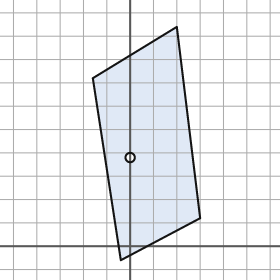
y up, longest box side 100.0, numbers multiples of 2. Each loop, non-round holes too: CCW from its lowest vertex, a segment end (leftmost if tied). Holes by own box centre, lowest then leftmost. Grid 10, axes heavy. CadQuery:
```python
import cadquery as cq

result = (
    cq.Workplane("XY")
    .moveTo(-4.0, -6.0)
    .lineTo(30.0, 12.0)
    .lineTo(20.0, 94.0)
    .lineTo(-16.0, 72.0)
    .close()
    .moveTo(0.0, 38.0)
    .circle(2.0)
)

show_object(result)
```